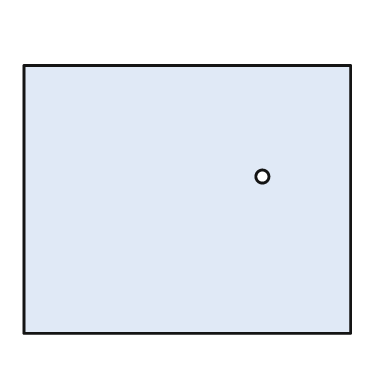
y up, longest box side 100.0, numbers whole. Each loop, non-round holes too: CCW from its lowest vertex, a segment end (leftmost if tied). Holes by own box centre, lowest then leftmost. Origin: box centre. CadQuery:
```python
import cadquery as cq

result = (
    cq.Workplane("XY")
    .moveTo(-50.0, -41.0)
    .lineTo(50.0, -41.0)
    .lineTo(50.0, 41.0)
    .lineTo(-50.0, 41.0)
    .close()
    .moveTo(23.0, 7.0)
    .circle(2.0)
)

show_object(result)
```